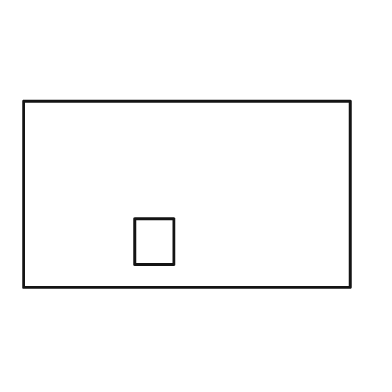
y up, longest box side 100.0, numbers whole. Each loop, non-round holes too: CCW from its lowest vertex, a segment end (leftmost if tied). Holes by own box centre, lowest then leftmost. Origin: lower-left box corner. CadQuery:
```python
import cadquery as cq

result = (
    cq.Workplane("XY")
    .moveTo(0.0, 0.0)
    .lineTo(100.0, 0.0)
    .lineTo(100.0, 57.0)
    .lineTo(0.0, 57.0)
    .close()
    .moveTo(34.0, 7.0)
    .lineTo(46.0, 7.0)
    .lineTo(46.0, 21.0)
    .lineTo(34.0, 21.0)
    .close()
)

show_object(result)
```